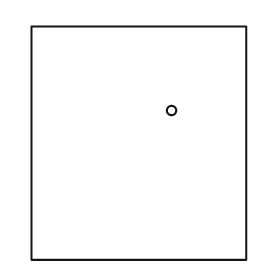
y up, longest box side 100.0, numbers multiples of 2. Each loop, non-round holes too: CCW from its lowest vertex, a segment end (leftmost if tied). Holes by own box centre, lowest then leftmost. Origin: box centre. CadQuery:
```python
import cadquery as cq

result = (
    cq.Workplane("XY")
    .moveTo(-46.0, -50.0)
    .lineTo(46.0, -50.0)
    .lineTo(46.0, 50.0)
    .lineTo(-46.0, 50.0)
    .close()
    .moveTo(14.0, 14.0)
    .circle(2.0)
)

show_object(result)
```